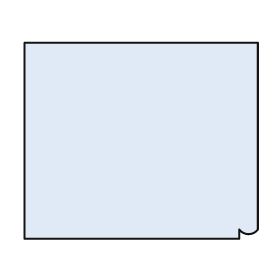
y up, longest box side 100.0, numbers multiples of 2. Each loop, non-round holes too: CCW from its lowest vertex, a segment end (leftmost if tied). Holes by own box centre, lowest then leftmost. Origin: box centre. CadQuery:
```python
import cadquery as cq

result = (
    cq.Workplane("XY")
    .moveTo(-50.0, -42.0)
    .lineTo(42.0, -42.0)
    .lineTo(42.0, -38.0)
    .threePointArc((46.0, -40.0), (50.0, -38.0))
    .lineTo(50.0, 42.0)
    .lineTo(-50.0, 42.0)
    .close()
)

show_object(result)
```